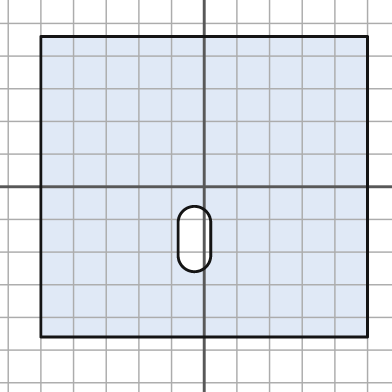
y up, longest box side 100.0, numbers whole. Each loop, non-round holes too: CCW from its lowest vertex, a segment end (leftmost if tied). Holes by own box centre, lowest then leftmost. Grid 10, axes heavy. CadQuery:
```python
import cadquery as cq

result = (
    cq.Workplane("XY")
    .moveTo(-50.0, -46.0)
    .lineTo(50.0, -46.0)
    .lineTo(50.0, 46.0)
    .lineTo(-50.0, 46.0)
    .close()
    .moveTo(-8.0, -21.0)
    .threePointArc((-3.0, -26.0), (2.0, -21.0))
    .lineTo(2.0, -11.0)
    .threePointArc((-3.0, -6.0), (-8.0, -11.0))
    .close()
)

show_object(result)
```